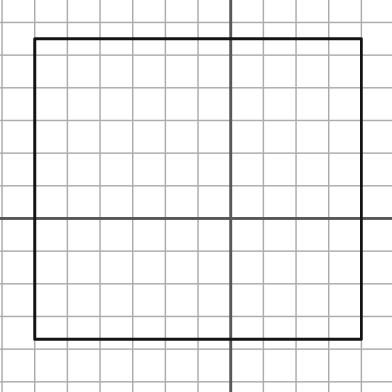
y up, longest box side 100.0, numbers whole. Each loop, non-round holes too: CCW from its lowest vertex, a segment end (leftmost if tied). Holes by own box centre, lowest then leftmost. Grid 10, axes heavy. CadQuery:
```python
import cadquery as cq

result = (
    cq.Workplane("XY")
    .moveTo(-60.0, -37.0)
    .lineTo(40.0, -37.0)
    .lineTo(40.0, 55.0)
    .lineTo(-60.0, 55.0)
    .close()
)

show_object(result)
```